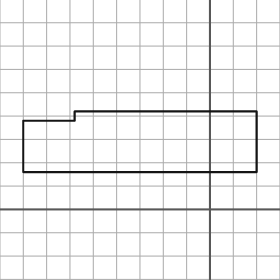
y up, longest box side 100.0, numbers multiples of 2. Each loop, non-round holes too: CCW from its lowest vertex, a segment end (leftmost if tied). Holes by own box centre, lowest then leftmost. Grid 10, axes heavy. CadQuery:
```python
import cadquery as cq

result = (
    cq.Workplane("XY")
    .moveTo(-80.0, 16.0)
    .lineTo(20.0, 16.0)
    .lineTo(20.0, 42.0)
    .lineTo(-58.0, 42.0)
    .lineTo(-58.0, 38.0)
    .lineTo(-80.0, 38.0)
    .close()
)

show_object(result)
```